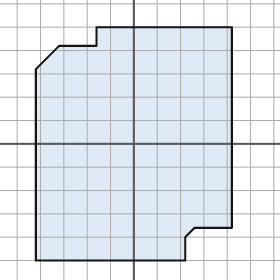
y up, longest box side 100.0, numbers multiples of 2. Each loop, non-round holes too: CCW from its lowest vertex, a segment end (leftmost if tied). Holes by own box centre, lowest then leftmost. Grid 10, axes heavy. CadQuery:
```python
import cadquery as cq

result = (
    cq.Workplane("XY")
    .moveTo(-42.0, -50.0)
    .lineTo(22.0, -50.0)
    .lineTo(22.0, -40.0)
    .lineTo(26.0, -36.0)
    .lineTo(42.0, -36.0)
    .lineTo(42.0, 50.0)
    .lineTo(-16.0, 50.0)
    .lineTo(-16.0, 42.0)
    .lineTo(-32.0, 42.0)
    .lineTo(-42.0, 32.0)
    .close()
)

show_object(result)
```